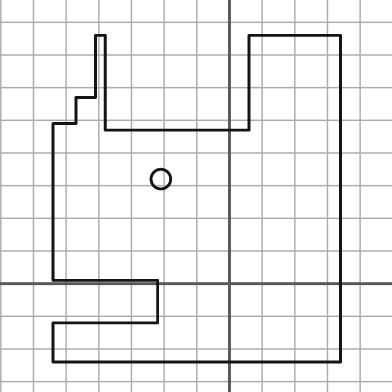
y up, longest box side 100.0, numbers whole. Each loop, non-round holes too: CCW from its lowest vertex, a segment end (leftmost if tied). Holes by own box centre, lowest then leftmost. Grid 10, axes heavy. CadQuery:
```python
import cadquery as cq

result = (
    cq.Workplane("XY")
    .moveTo(-54.0, -24.0)
    .lineTo(34.0, -24.0)
    .lineTo(34.0, 76.0)
    .lineTo(6.0, 76.0)
    .lineTo(6.0, 47.0)
    .lineTo(-38.0, 47.0)
    .lineTo(-38.0, 76.0)
    .lineTo(-41.0, 76.0)
    .lineTo(-41.0, 57.0)
    .lineTo(-47.0, 57.0)
    .lineTo(-47.0, 49.0)
    .lineTo(-54.0, 49.0)
    .lineTo(-54.0, 1.0)
    .lineTo(-22.0, 1.0)
    .lineTo(-22.0, -12.0)
    .lineTo(-54.0, -12.0)
    .close()
    .moveTo(-21.0, 32.0)
    .circle(3.0)
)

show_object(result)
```